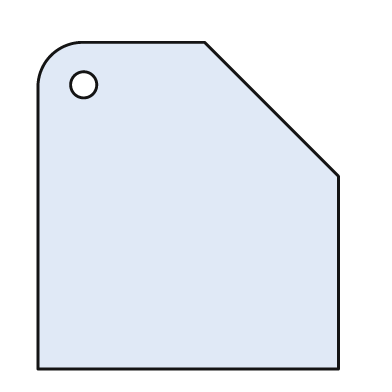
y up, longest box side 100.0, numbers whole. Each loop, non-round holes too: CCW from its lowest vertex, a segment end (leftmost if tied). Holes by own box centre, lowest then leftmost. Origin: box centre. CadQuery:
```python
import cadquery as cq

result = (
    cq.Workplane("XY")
    .moveTo(-46.0, -50.0)
    .lineTo(46.0, -50.0)
    .lineTo(46.0, 9.0)
    .lineTo(5.0, 50.0)
    .lineTo(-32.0, 50.0)
    .threePointArc((-42.0, 46.0), (-46.0, 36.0))
    .close()
    .moveTo(-32.0, 37.0)
    .circle(4.0)
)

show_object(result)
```